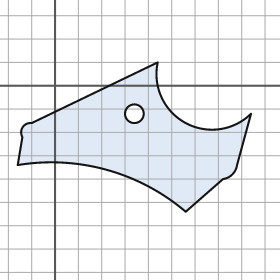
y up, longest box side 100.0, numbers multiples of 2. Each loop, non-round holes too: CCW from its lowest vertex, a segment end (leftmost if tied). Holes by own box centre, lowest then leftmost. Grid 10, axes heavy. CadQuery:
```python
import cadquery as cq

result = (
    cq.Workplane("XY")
    .moveTo(56.0, -54.0)
    .lineTo(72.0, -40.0)
    .threePointArc((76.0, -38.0), (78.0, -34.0))
    .lineTo(84.0, -12.0)
    .threePointArc((56.0, -16.0), (44.0, 10.0))
    .lineTo(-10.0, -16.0)
    .threePointArc((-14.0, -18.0), (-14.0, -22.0))
    .lineTo(-16.0, -34.0)
    .threePointArc((22.0, -36.0), (56.0, -54.0))
    .close()
    .moveTo(34.0, -12.0)
    .circle(4.0)
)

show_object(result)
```